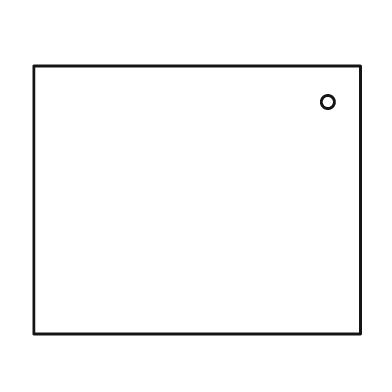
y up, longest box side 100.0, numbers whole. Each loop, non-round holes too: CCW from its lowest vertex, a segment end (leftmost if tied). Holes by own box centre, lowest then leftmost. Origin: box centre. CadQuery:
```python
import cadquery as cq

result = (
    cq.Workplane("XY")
    .moveTo(-50.0, -41.0)
    .lineTo(50.0, -41.0)
    .lineTo(50.0, 41.0)
    .lineTo(-50.0, 41.0)
    .close()
    .moveTo(40.0, 30.0)
    .circle(2.0)
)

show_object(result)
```